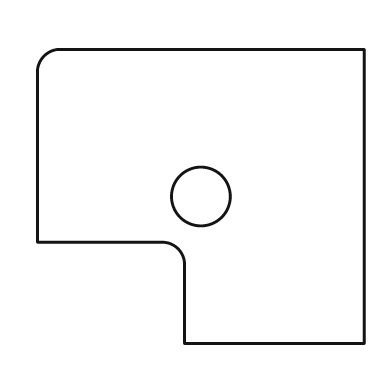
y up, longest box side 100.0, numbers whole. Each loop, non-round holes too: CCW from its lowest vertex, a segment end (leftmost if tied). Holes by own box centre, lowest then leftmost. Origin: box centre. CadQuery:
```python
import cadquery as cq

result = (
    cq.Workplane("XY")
    .moveTo(-5.0, -45.0)
    .lineTo(50.0, -45.0)
    .lineTo(50.0, 45.0)
    .lineTo(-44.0, 45.0)
    .threePointArc((-48.0, 43.0), (-50.0, 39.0))
    .lineTo(-50.0, -14.0)
    .lineTo(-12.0, -14.0)
    .threePointArc((-7.0, -16.0), (-5.0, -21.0))
    .close()
    .moveTo(0.0, 0.0)
    .circle(9.0)
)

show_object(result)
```